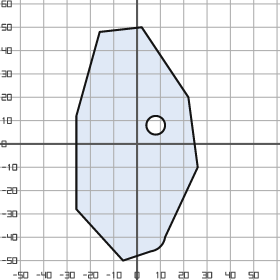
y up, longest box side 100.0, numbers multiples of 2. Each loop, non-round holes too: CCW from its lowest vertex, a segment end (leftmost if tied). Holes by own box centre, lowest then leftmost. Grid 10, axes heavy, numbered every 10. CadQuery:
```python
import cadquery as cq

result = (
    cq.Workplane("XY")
    .moveTo(-6.0, -50.0)
    .lineTo(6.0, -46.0)
    .threePointArc((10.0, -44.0), (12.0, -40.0))
    .lineTo(26.0, -10.0)
    .lineTo(22.0, 20.0)
    .lineTo(2.0, 50.0)
    .lineTo(-16.0, 48.0)
    .lineTo(-26.0, 12.0)
    .lineTo(-26.0, -28.0)
    .close()
    .moveTo(8.0, 8.0)
    .circle(4.0)
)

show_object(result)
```